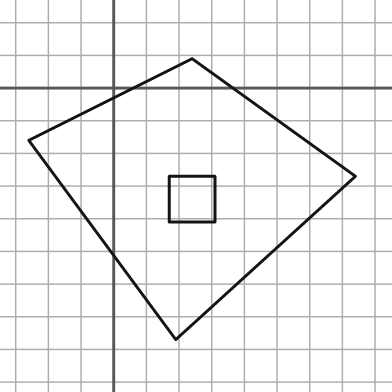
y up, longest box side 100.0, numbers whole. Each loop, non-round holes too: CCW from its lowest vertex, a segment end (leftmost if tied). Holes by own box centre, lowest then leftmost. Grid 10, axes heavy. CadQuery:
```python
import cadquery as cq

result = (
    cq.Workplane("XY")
    .moveTo(19.0, -77.0)
    .lineTo(74.0, -27.0)
    .lineTo(24.0, 9.0)
    .lineTo(-26.0, -16.0)
    .close()
    .moveTo(17.0, -41.0)
    .lineTo(31.0, -41.0)
    .lineTo(31.0, -27.0)
    .lineTo(17.0, -27.0)
    .close()
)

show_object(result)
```